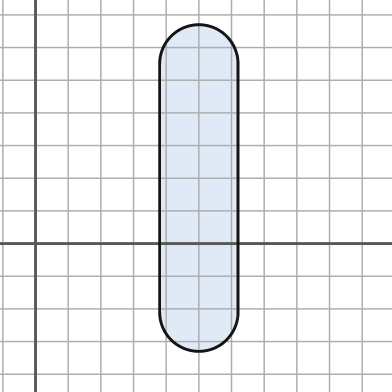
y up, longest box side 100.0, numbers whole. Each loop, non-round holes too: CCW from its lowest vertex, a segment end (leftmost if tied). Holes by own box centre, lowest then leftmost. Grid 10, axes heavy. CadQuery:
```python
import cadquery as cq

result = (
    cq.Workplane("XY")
    .moveTo(38.0, -21.0)
    .threePointArc((50.0, -33.0), (62.0, -21.0))
    .lineTo(62.0, 55.0)
    .threePointArc((50.0, 67.0), (38.0, 55.0))
    .close()
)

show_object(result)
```